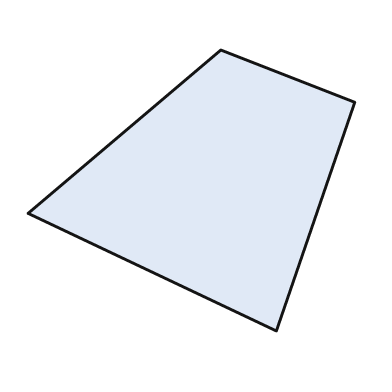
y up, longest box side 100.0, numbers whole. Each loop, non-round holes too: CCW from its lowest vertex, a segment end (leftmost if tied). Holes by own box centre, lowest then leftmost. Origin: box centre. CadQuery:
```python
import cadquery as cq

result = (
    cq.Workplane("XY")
    .moveTo(26.0, -43.0)
    .lineTo(50.0, 27.0)
    .lineTo(9.0, 43.0)
    .lineTo(-50.0, -7.0)
    .close()
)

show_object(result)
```